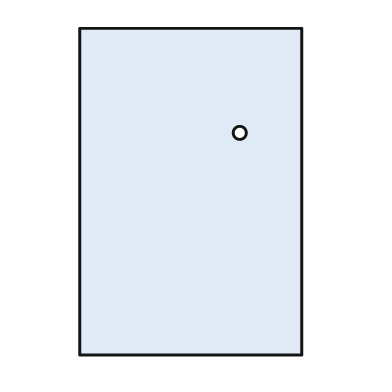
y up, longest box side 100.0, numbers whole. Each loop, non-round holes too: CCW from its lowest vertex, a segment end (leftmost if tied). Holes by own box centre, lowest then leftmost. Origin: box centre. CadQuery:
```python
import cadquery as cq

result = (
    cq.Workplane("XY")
    .moveTo(-34.0, -50.0)
    .lineTo(34.0, -50.0)
    .lineTo(34.0, 50.0)
    .lineTo(-34.0, 50.0)
    .close()
    .moveTo(15.0, 18.0)
    .circle(2.0)
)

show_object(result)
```